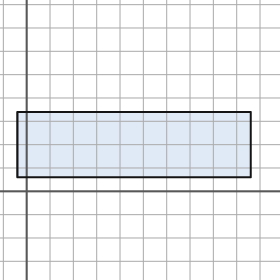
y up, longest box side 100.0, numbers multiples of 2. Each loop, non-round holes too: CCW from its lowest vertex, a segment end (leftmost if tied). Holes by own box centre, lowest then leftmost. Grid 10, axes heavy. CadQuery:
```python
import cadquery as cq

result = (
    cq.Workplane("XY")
    .moveTo(-4.0, 6.0)
    .lineTo(96.0, 6.0)
    .lineTo(96.0, 34.0)
    .lineTo(-4.0, 34.0)
    .close()
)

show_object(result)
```